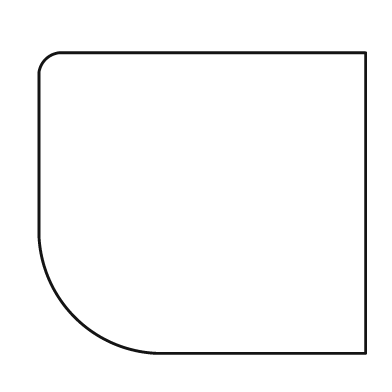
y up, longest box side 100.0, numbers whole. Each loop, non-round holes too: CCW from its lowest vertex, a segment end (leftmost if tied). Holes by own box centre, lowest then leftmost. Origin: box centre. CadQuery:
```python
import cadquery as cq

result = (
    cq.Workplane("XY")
    .moveTo(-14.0, -46.0)
    .lineTo(50.0, -46.0)
    .lineTo(50.0, 46.0)
    .lineTo(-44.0, 46.0)
    .threePointArc((-48.0, 44.0), (-50.0, 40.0))
    .lineTo(-50.0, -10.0)
    .threePointArc((-39.0, -35.0), (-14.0, -46.0))
    .close()
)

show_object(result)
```